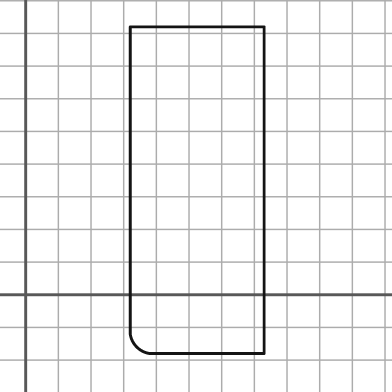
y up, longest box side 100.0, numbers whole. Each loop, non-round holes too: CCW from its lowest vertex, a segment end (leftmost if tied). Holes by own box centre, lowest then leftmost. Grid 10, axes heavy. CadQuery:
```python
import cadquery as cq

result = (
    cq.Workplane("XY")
    .moveTo(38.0, -18.0)
    .lineTo(73.0, -18.0)
    .lineTo(73.0, 82.0)
    .lineTo(32.0, 82.0)
    .lineTo(32.0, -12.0)
    .threePointArc((34.0, -16.0), (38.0, -18.0))
    .close()
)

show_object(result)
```